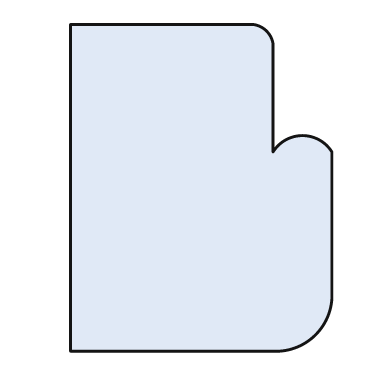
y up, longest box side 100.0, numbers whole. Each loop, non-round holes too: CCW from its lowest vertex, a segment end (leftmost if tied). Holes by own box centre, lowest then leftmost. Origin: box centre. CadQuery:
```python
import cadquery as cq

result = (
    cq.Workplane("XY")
    .moveTo(-40.0, -50.0)
    .lineTo(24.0, -50.0)
    .threePointArc((35.0, -45.0), (40.0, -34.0))
    .lineTo(40.0, 11.0)
    .threePointArc((31.0, 16.0), (22.0, 11.0))
    .lineTo(22.0, 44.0)
    .threePointArc((20.0, 48.0), (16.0, 50.0))
    .lineTo(-40.0, 50.0)
    .close()
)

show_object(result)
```